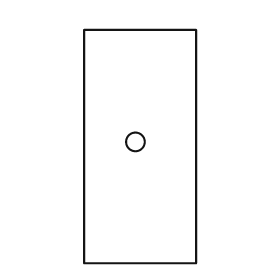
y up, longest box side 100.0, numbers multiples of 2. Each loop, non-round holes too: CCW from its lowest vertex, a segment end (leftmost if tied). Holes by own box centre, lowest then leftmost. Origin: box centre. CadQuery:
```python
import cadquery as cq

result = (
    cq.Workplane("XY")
    .moveTo(-24.0, -50.0)
    .lineTo(24.0, -50.0)
    .lineTo(24.0, 50.0)
    .lineTo(-24.0, 50.0)
    .close()
    .moveTo(-2.0, 2.0)
    .circle(4.0)
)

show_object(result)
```